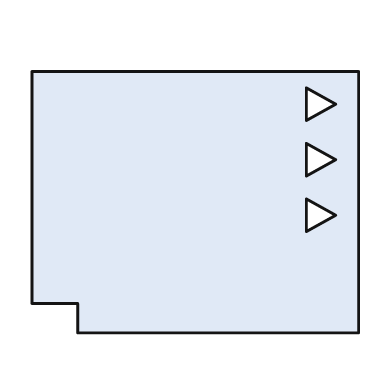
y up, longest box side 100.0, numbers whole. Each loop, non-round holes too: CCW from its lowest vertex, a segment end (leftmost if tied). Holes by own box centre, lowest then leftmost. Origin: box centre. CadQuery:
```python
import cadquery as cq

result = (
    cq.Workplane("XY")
    .moveTo(-36.0, -40.0)
    .lineTo(50.0, -40.0)
    .lineTo(50.0, 40.0)
    .lineTo(-50.0, 40.0)
    .lineTo(-50.0, -31.0)
    .lineTo(-36.0, -31.0)
    .close()
    .moveTo(34.0, -9.0)
    .lineTo(43.0, -4.0)
    .lineTo(34.0, 1.0)
    .close()
    .moveTo(34.0, 8.0)
    .lineTo(43.0, 13.0)
    .lineTo(34.0, 18.0)
    .close()
    .moveTo(34.0, 25.0)
    .lineTo(43.0, 30.0)
    .lineTo(34.0, 35.0)
    .close()
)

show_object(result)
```